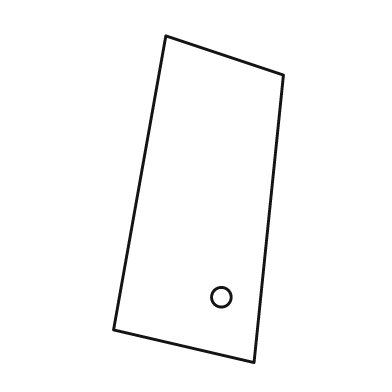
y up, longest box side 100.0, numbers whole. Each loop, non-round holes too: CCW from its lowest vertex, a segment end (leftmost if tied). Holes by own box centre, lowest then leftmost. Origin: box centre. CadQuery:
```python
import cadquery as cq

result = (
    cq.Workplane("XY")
    .moveTo(17.0, -50.0)
    .lineTo(26.0, 38.0)
    .lineTo(-10.0, 50.0)
    .lineTo(-26.0, -40.0)
    .close()
    .moveTo(7.0, -30.0)
    .circle(3.0)
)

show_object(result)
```